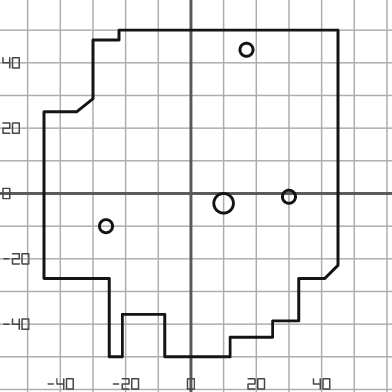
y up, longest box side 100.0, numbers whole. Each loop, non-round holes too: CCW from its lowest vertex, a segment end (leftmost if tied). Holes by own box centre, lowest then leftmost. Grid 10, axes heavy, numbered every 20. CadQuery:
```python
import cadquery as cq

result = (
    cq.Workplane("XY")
    .moveTo(-25.0, -50.0)
    .lineTo(-21.0, -50.0)
    .lineTo(-21.0, -37.0)
    .lineTo(-8.0, -37.0)
    .lineTo(-8.0, -50.0)
    .lineTo(12.0, -50.0)
    .lineTo(12.0, -44.0)
    .lineTo(25.0, -44.0)
    .lineTo(25.0, -39.0)
    .lineTo(33.0, -39.0)
    .lineTo(33.0, -26.0)
    .lineTo(41.0, -26.0)
    .lineTo(45.0, -22.0)
    .lineTo(45.0, 50.0)
    .lineTo(-22.0, 50.0)
    .lineTo(-22.0, 47.0)
    .lineTo(-30.0, 47.0)
    .lineTo(-30.0, 29.0)
    .lineTo(-35.0, 25.0)
    .lineTo(-45.0, 25.0)
    .lineTo(-45.0, -26.0)
    .lineTo(-25.0, -26.0)
    .close()
    .moveTo(-26.0, -10.0)
    .circle(2.0)
    .moveTo(10.0, -3.0)
    .circle(3.0)
    .moveTo(30.0, -1.0)
    .circle(2.0)
    .moveTo(17.0, 44.0)
    .circle(2.0)
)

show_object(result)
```